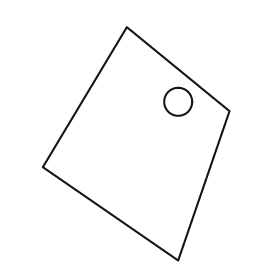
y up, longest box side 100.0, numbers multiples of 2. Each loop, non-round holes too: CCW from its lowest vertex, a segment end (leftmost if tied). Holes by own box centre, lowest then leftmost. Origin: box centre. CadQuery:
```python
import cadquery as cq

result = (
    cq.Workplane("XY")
    .moveTo(18.0, -50.0)
    .lineTo(40.0, 14.0)
    .lineTo(-4.0, 50.0)
    .lineTo(-40.0, -10.0)
    .close()
    .moveTo(18.0, 18.0)
    .circle(6.0)
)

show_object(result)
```